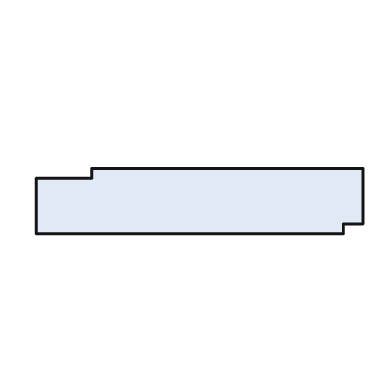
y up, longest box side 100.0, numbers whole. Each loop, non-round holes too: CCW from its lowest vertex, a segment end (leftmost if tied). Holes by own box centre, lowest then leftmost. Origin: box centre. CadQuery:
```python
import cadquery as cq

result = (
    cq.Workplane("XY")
    .moveTo(-50.0, -10.0)
    .lineTo(44.0, -10.0)
    .lineTo(44.0, -7.0)
    .lineTo(50.0, -7.0)
    .lineTo(50.0, 10.0)
    .lineTo(-33.0, 10.0)
    .lineTo(-33.0, 7.0)
    .lineTo(-50.0, 7.0)
    .close()
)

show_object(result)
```